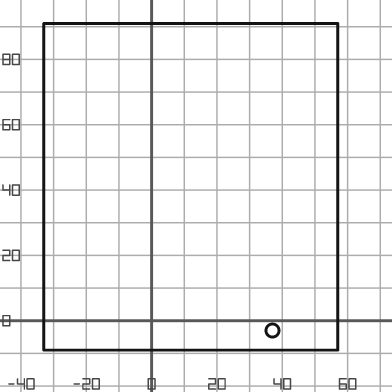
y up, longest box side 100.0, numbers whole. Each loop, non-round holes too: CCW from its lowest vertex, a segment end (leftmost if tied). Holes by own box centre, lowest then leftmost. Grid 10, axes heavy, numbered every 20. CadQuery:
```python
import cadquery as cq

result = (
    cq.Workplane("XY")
    .moveTo(-33.0, -9.0)
    .lineTo(57.0, -9.0)
    .lineTo(57.0, 91.0)
    .lineTo(-33.0, 91.0)
    .close()
    .moveTo(37.0, -3.0)
    .circle(2.0)
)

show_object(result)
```